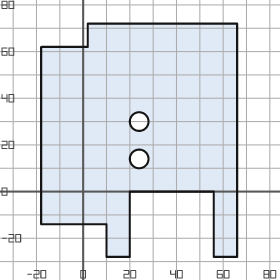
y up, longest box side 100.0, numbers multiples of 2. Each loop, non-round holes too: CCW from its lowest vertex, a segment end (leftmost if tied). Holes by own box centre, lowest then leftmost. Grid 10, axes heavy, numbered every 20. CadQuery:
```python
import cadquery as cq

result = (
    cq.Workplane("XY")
    .moveTo(10.0, -28.0)
    .lineTo(20.0, -28.0)
    .lineTo(20.0, 0.0)
    .lineTo(56.0, 0.0)
    .lineTo(56.0, -28.0)
    .lineTo(66.0, -28.0)
    .lineTo(66.0, 72.0)
    .lineTo(2.0, 72.0)
    .lineTo(2.0, 62.0)
    .lineTo(-18.0, 62.0)
    .lineTo(-18.0, -14.0)
    .lineTo(10.0, -14.0)
    .close()
    .moveTo(24.0, 14.0)
    .circle(4.0)
    .moveTo(24.0, 30.0)
    .circle(4.0)
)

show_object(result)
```